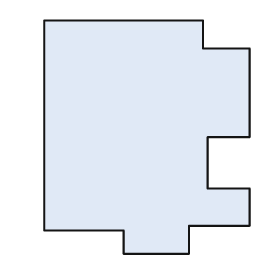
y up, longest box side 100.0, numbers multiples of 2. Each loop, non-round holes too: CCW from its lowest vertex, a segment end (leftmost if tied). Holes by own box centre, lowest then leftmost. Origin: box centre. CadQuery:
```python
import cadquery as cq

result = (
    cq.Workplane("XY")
    .moveTo(-10.0, -50.0)
    .lineTo(18.0, -50.0)
    .lineTo(18.0, -38.0)
    .lineTo(44.0, -38.0)
    .lineTo(44.0, -22.0)
    .lineTo(26.0, -22.0)
    .lineTo(26.0, 0.0)
    .lineTo(44.0, 0.0)
    .lineTo(44.0, 38.0)
    .lineTo(24.0, 38.0)
    .lineTo(24.0, 50.0)
    .lineTo(-44.0, 50.0)
    .lineTo(-44.0, -40.0)
    .lineTo(-10.0, -40.0)
    .close()
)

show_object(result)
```